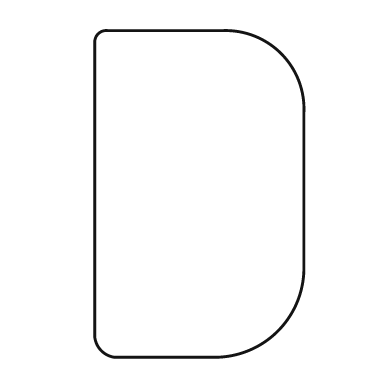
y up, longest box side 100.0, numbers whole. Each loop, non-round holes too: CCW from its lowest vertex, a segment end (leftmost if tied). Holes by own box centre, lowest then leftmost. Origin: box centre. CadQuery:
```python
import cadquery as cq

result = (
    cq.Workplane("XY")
    .moveTo(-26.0, -50.0)
    .lineTo(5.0, -50.0)
    .threePointArc((24.0, -42.0), (32.0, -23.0))
    .lineTo(32.0, 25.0)
    .threePointArc((25.0, 43.0), (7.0, 50.0))
    .lineTo(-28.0, 50.0)
    .threePointArc((-31.0, 49.0), (-32.0, 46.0))
    .lineTo(-32.0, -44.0)
    .threePointArc((-30.0, -48.0), (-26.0, -50.0))
    .close()
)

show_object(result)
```